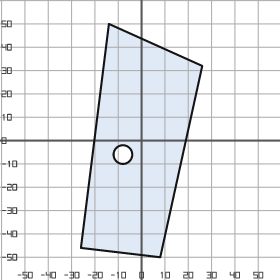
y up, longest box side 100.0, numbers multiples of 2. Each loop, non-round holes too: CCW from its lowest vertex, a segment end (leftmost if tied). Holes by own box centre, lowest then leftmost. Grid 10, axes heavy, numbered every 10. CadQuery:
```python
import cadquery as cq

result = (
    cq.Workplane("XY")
    .moveTo(8.0, -50.0)
    .lineTo(26.0, 32.0)
    .lineTo(-14.0, 50.0)
    .lineTo(-26.0, -46.0)
    .close()
    .moveTo(-8.0, -6.0)
    .circle(4.0)
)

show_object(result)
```